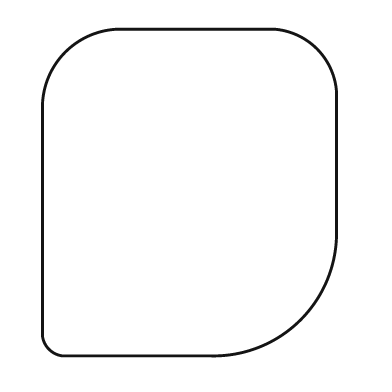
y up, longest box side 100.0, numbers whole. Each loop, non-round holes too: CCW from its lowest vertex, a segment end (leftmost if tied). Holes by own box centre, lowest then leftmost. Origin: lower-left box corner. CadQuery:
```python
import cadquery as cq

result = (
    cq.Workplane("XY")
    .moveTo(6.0, 0.0)
    .lineTo(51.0, 0.0)
    .threePointArc((79.0, 11.0), (90.0, 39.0))
    .lineTo(90.0, 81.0)
    .threePointArc((84.0, 94.0), (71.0, 100.0))
    .lineTo(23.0, 100.0)
    .threePointArc((7.0, 93.0), (0.0, 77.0))
    .lineTo(0.0, 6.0)
    .threePointArc((2.0, 2.0), (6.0, 0.0))
    .close()
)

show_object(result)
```